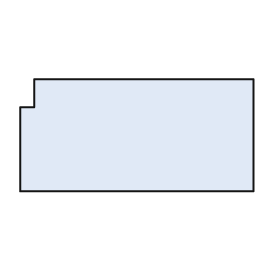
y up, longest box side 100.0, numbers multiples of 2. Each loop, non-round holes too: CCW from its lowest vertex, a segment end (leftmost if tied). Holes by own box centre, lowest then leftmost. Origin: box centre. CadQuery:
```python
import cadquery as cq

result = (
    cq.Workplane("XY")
    .moveTo(-50.0, -24.0)
    .lineTo(50.0, -24.0)
    .lineTo(50.0, 24.0)
    .lineTo(-44.0, 24.0)
    .lineTo(-44.0, 12.0)
    .lineTo(-50.0, 12.0)
    .close()
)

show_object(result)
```